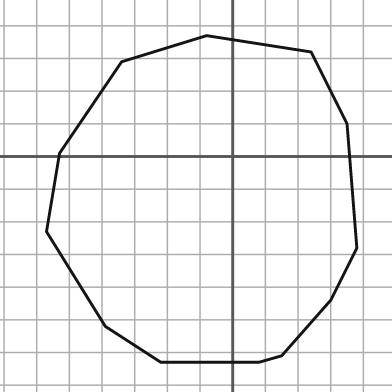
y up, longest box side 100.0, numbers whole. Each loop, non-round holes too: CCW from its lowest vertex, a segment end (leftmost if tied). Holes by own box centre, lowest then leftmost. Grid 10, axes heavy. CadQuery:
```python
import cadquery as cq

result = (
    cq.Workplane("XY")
    .moveTo(-22.0, -63.0)
    .lineTo(8.0, -63.0)
    .lineTo(15.0, -61.0)
    .lineTo(30.0, -44.0)
    .lineTo(38.0, -28.0)
    .lineTo(35.0, 10.0)
    .lineTo(24.0, 32.0)
    .lineTo(-8.0, 37.0)
    .lineTo(-34.0, 29.0)
    .lineTo(-53.0, 1.0)
    .lineTo(-57.0, -23.0)
    .lineTo(-39.0, -52.0)
    .close()
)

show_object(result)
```